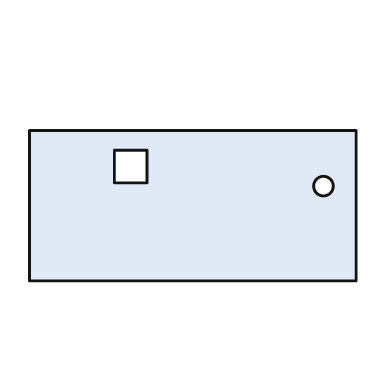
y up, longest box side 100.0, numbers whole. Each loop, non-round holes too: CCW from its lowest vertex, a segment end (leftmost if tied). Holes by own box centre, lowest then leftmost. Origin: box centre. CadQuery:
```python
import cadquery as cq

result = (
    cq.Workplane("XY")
    .moveTo(-50.0, -23.0)
    .lineTo(50.0, -23.0)
    .lineTo(50.0, 23.0)
    .lineTo(-50.0, 23.0)
    .close()
    .moveTo(40.0, 6.0)
    .circle(3.0)
    .moveTo(-24.0, 7.0)
    .lineTo(-14.0, 7.0)
    .lineTo(-14.0, 17.0)
    .lineTo(-24.0, 17.0)
    .close()
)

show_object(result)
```